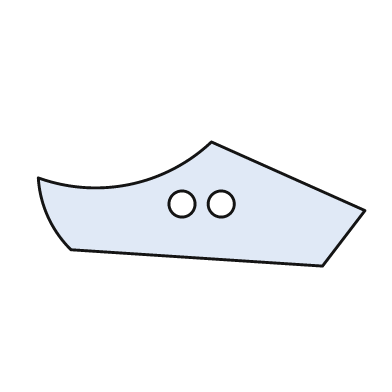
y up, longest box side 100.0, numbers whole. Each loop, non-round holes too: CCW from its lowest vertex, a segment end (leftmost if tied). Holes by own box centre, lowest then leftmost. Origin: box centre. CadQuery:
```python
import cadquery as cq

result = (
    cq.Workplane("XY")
    .moveTo(37.0, -19.0)
    .lineTo(50.0, -2.0)
    .lineTo(3.0, 19.0)
    .threePointArc((-22.0, 6.0), (-50.0, 8.0))
    .threePointArc((-47.0, -4.0), (-40.0, -14.0))
    .close()
    .moveTo(-6.0, 0.0)
    .circle(4.0)
    .moveTo(6.0, 0.0)
    .circle(4.0)
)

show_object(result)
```